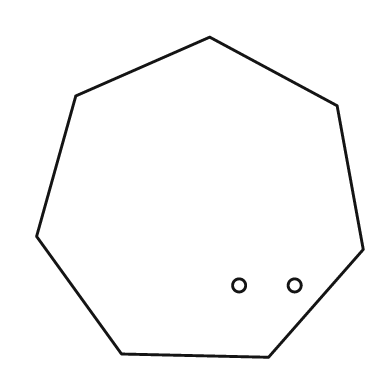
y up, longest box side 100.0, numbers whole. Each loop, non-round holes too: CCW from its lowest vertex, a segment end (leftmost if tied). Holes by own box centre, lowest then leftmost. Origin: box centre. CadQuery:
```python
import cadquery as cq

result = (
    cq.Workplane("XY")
    .moveTo(21.0, -49.0)
    .lineTo(50.0, -16.0)
    .lineTo(42.0, 28.0)
    .lineTo(3.0, 49.0)
    .lineTo(-38.0, 31.0)
    .lineTo(-50.0, -12.0)
    .lineTo(-24.0, -48.0)
    .close()
    .moveTo(12.0, -27.0)
    .circle(2.0)
    .moveTo(29.0, -27.0)
    .circle(2.0)
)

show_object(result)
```